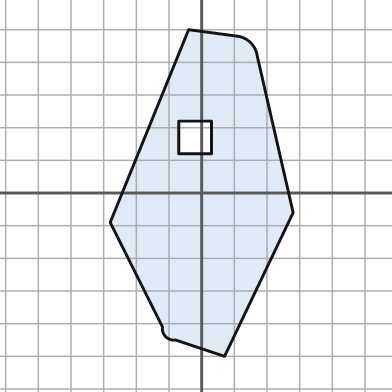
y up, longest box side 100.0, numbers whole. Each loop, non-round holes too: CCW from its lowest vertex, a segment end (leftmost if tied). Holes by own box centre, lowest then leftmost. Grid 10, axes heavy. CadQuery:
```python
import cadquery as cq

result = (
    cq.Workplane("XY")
    .moveTo(7.0, -50.0)
    .lineTo(28.0, -6.0)
    .lineTo(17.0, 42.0)
    .threePointArc((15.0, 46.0), (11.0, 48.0))
    .lineTo(-4.0, 50.0)
    .lineTo(-28.0, -9.0)
    .lineTo(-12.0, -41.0)
    .threePointArc((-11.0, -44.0), (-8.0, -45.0))
    .close()
    .moveTo(-7.0, 12.0)
    .lineTo(3.0, 12.0)
    .lineTo(3.0, 22.0)
    .lineTo(-7.0, 22.0)
    .close()
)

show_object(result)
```